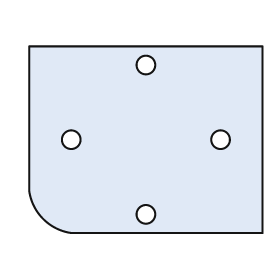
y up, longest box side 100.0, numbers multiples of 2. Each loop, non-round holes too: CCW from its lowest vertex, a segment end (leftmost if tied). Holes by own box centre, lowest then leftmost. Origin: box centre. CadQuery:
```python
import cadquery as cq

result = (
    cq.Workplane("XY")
    .moveTo(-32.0, -40.0)
    .lineTo(50.0, -40.0)
    .lineTo(50.0, 40.0)
    .lineTo(-50.0, 40.0)
    .lineTo(-50.0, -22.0)
    .threePointArc((-44.0, -34.0), (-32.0, -40.0))
    .close()
    .moveTo(0.0, -32.0)
    .circle(4.0)
    .moveTo(-32.0, 0.0)
    .circle(4.0)
    .moveTo(32.0, 0.0)
    .circle(4.0)
    .moveTo(0.0, 32.0)
    .circle(4.0)
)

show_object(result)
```